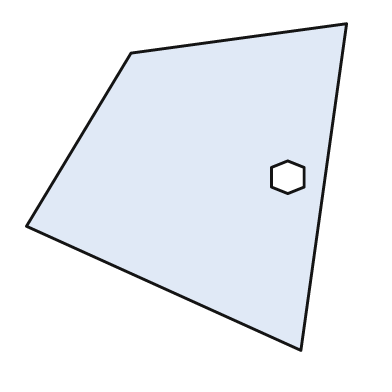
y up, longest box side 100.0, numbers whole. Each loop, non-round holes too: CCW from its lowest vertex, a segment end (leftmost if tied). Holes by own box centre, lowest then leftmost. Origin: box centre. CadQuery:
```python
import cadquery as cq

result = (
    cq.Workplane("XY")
    .moveTo(35.0, -50.0)
    .lineTo(49.0, 50.0)
    .lineTo(-17.0, 41.0)
    .lineTo(-49.0, -12.0)
    .close()
    .moveTo(31.0, -2.0)
    .lineTo(36.0, 0.0)
    .lineTo(36.0, 6.0)
    .lineTo(31.0, 8.0)
    .lineTo(26.0, 6.0)
    .lineTo(26.0, 0.0)
    .close()
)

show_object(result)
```